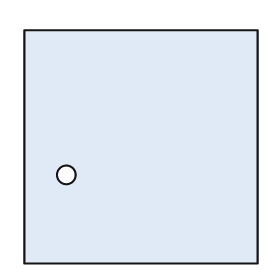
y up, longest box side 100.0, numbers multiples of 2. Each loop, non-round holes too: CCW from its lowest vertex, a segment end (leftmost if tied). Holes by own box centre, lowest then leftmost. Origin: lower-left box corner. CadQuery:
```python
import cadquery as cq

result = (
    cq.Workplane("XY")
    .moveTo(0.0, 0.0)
    .lineTo(100.0, 0.0)
    .lineTo(100.0, 100.0)
    .lineTo(0.0, 100.0)
    .close()
    .moveTo(18.0, 38.0)
    .circle(4.0)
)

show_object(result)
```